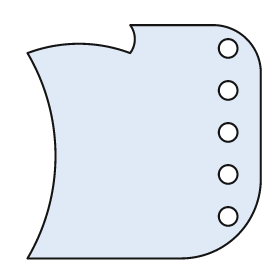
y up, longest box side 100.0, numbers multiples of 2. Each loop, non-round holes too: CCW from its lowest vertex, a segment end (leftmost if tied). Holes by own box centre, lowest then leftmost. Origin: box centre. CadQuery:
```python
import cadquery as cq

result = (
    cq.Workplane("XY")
    .moveTo(-50.0, -50.0)
    .lineTo(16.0, -50.0)
    .threePointArc((40.0, -40.0), (50.0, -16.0))
    .lineTo(50.0, 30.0)
    .threePointArc((44.0, 44.0), (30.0, 50.0))
    .lineTo(-6.0, 50.0)
    .threePointArc((-4.0, 44.0), (-6.0, 38.0))
    .threePointArc((-28.0, 42.0), (-50.0, 38.0))
    .threePointArc((-38.0, -6.0), (-50.0, -50.0))
    .close()
    .moveTo(36.0, -32.0)
    .circle(4.0)
    .moveTo(36.0, -14.0)
    .circle(4.0)
    .moveTo(36.0, 4.0)
    .circle(4.0)
    .moveTo(36.0, 22.0)
    .circle(4.0)
    .moveTo(36.0, 40.0)
    .circle(4.0)
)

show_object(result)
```